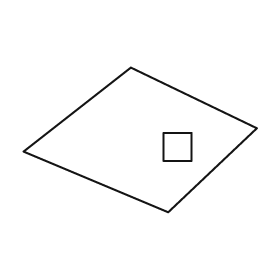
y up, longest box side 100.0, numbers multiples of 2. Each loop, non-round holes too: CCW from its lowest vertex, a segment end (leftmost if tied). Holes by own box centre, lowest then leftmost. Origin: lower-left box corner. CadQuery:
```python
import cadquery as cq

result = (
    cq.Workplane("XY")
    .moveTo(62.0, 0.0)
    .lineTo(100.0, 36.0)
    .lineTo(46.0, 62.0)
    .lineTo(0.0, 26.0)
    .close()
    .moveTo(60.0, 22.0)
    .lineTo(72.0, 22.0)
    .lineTo(72.0, 34.0)
    .lineTo(60.0, 34.0)
    .close()
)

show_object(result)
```